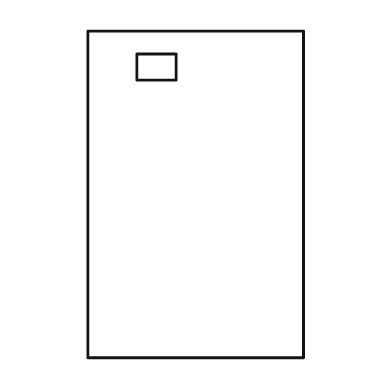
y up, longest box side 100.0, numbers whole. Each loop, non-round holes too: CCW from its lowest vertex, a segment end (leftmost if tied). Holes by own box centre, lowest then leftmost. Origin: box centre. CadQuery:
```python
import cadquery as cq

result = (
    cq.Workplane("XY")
    .moveTo(-33.0, -50.0)
    .lineTo(33.0, -50.0)
    .lineTo(33.0, 50.0)
    .lineTo(-33.0, 50.0)
    .close()
    .moveTo(-18.0, 35.0)
    .lineTo(-6.0, 35.0)
    .lineTo(-6.0, 43.0)
    .lineTo(-18.0, 43.0)
    .close()
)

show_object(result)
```